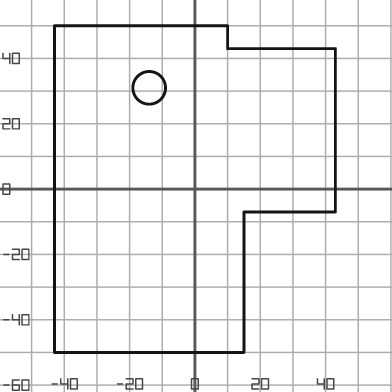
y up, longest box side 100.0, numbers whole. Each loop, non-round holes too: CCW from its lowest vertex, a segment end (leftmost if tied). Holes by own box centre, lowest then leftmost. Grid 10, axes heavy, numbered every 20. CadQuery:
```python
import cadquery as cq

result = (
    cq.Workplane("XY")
    .moveTo(-43.0, -50.0)
    .lineTo(15.0, -50.0)
    .lineTo(15.0, -7.0)
    .lineTo(43.0, -7.0)
    .lineTo(43.0, 43.0)
    .lineTo(10.0, 43.0)
    .lineTo(10.0, 50.0)
    .lineTo(-43.0, 50.0)
    .close()
    .moveTo(-14.0, 31.0)
    .circle(5.0)
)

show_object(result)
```